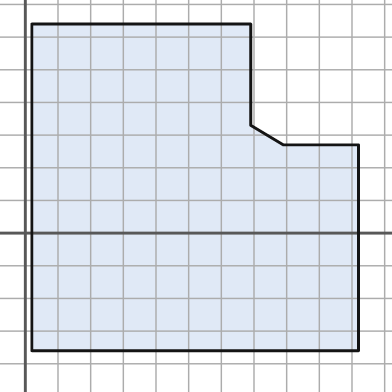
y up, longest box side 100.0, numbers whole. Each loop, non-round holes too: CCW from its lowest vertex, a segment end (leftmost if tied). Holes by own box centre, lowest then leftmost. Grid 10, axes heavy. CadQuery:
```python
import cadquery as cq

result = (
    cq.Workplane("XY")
    .moveTo(2.0, -36.0)
    .lineTo(102.0, -36.0)
    .lineTo(102.0, 27.0)
    .lineTo(79.0, 27.0)
    .lineTo(69.0, 33.0)
    .lineTo(69.0, 64.0)
    .lineTo(2.0, 64.0)
    .close()
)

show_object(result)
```